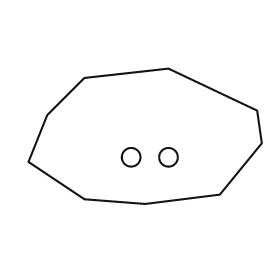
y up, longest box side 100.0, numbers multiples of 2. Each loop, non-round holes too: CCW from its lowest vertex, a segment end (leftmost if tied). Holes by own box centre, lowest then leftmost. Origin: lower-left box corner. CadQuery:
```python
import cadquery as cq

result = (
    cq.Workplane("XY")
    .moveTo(50.0, 0.0)
    .lineTo(82.0, 4.0)
    .lineTo(100.0, 26.0)
    .lineTo(98.0, 40.0)
    .lineTo(60.0, 58.0)
    .lineTo(24.0, 54.0)
    .lineTo(8.0, 38.0)
    .lineTo(0.0, 18.0)
    .lineTo(24.0, 2.0)
    .close()
    .moveTo(44.0, 20.0)
    .circle(4.0)
    .moveTo(60.0, 20.0)
    .circle(4.0)
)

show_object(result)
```